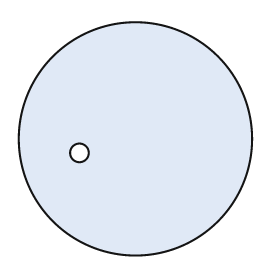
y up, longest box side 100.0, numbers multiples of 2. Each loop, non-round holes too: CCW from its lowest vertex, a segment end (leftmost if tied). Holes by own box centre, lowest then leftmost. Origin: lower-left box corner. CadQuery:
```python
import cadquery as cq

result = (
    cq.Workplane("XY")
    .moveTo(50.0, 50.0)
    .circle(50.0)
    .moveTo(26.0, 44.0)
    .circle(4.0)
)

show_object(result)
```